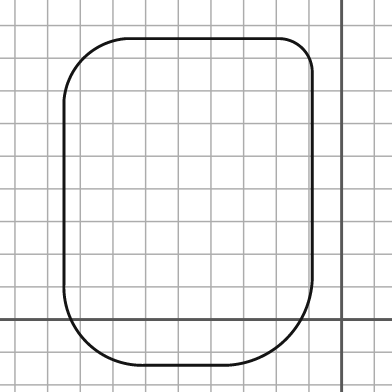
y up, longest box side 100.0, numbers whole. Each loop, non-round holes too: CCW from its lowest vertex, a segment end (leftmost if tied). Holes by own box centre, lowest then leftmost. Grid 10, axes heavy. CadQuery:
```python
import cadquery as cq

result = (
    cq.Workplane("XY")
    .moveTo(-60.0, -14.0)
    .lineTo(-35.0, -14.0)
    .threePointArc((-17.0, -6.0), (-9.0, 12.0))
    .lineTo(-9.0, 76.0)
    .threePointArc((-12.0, 83.0), (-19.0, 86.0))
    .lineTo(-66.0, 86.0)
    .threePointArc((-79.0, 80.0), (-85.0, 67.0))
    .lineTo(-85.0, 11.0)
    .threePointArc((-78.0, -7.0), (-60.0, -14.0))
    .close()
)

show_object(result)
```